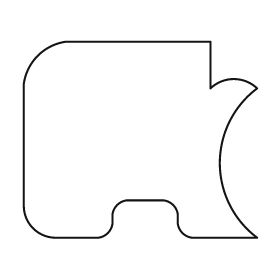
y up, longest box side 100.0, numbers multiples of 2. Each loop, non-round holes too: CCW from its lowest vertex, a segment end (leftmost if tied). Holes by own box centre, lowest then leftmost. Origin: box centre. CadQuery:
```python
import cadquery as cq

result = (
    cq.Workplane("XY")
    .moveTo(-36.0, -42.0)
    .lineTo(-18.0, -42.0)
    .threePointArc((-14.0, -40.0), (-12.0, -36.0))
    .lineTo(-12.0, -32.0)
    .threePointArc((-10.0, -28.0), (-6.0, -26.0))
    .lineTo(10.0, -26.0)
    .threePointArc((14.0, -28.0), (16.0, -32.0))
    .lineTo(16.0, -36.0)
    .threePointArc((18.0, -40.0), (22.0, -42.0))
    .lineTo(50.0, -42.0)
    .threePointArc((34.0, -10.0), (50.0, 22.0))
    .threePointArc((40.0, 26.0), (30.0, 22.0))
    .lineTo(30.0, 42.0)
    .lineTo(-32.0, 42.0)
    .threePointArc((-44.0, 36.0), (-50.0, 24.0))
    .lineTo(-50.0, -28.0)
    .threePointArc((-46.0, -38.0), (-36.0, -42.0))
    .close()
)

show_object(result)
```